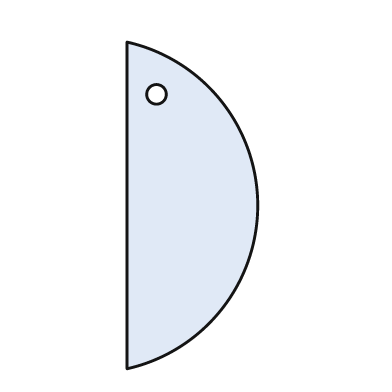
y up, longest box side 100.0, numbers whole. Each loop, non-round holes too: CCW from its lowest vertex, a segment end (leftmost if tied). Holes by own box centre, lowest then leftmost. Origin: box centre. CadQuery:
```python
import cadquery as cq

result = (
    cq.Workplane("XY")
    .moveTo(-20.0, -50.0)
    .threePointArc((20.0, 0.0), (-20.0, 50.0))
    .close()
    .moveTo(-11.0, 34.0)
    .circle(3.0)
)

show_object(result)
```